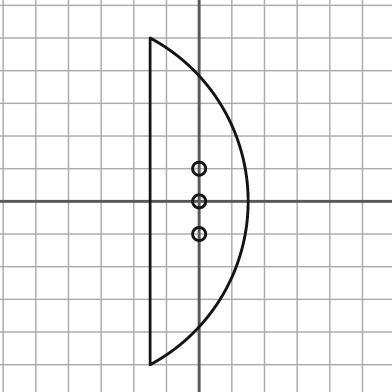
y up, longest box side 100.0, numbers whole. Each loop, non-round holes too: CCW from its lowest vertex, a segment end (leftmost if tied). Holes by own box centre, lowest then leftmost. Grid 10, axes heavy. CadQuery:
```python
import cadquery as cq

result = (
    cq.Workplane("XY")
    .moveTo(-15.0, -50.0)
    .threePointArc((15.0, 0.0), (-15.0, 50.0))
    .close()
    .moveTo(0.0, -10.0)
    .circle(2.0)
    .moveTo(0.0, 0.0)
    .circle(2.0)
    .moveTo(0.0, 10.0)
    .circle(2.0)
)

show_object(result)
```